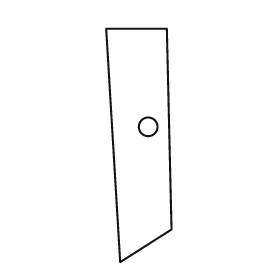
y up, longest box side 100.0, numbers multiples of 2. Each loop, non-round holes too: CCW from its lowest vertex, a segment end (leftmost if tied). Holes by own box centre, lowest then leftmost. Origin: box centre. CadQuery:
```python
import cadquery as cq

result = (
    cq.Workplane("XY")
    .moveTo(-8.0, -50.0)
    .lineTo(14.0, -36.0)
    .lineTo(12.0, 50.0)
    .lineTo(-14.0, 50.0)
    .close()
    .moveTo(4.0, 8.0)
    .circle(4.0)
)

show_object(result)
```